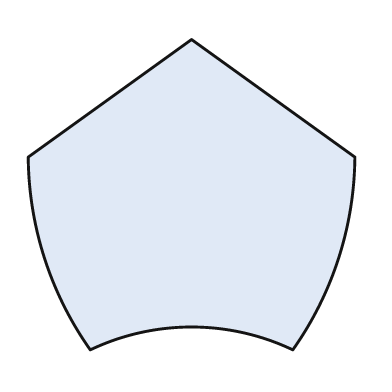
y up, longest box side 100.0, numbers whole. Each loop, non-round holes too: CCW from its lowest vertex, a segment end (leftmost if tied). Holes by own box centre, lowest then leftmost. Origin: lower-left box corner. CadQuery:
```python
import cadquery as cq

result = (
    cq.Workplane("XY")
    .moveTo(19.0, 0.0)
    .threePointArc((50.0, 7.0), (81.0, 0.0))
    .threePointArc((95.0, 28.0), (100.0, 59.0))
    .lineTo(50.0, 95.0)
    .lineTo(0.0, 59.0)
    .threePointArc((5.0, 28.0), (19.0, 0.0))
    .close()
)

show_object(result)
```